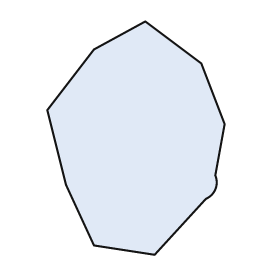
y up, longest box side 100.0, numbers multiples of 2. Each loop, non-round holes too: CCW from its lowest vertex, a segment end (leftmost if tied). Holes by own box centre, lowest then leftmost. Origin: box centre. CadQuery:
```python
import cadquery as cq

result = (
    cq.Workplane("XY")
    .moveTo(8.0, -50.0)
    .lineTo(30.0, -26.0)
    .threePointArc((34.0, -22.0), (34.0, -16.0))
    .lineTo(38.0, 6.0)
    .lineTo(28.0, 32.0)
    .lineTo(4.0, 50.0)
    .lineTo(-18.0, 38.0)
    .lineTo(-38.0, 12.0)
    .lineTo(-30.0, -20.0)
    .lineTo(-18.0, -46.0)
    .close()
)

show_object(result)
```